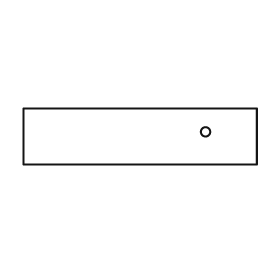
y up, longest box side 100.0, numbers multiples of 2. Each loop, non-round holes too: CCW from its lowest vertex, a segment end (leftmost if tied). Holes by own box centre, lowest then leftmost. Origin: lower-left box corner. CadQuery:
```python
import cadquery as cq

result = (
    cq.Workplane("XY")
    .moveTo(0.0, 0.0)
    .lineTo(100.0, 0.0)
    .lineTo(100.0, 24.0)
    .lineTo(0.0, 24.0)
    .close()
    .moveTo(78.0, 14.0)
    .circle(2.0)
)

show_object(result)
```